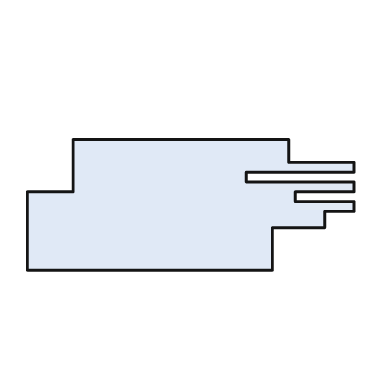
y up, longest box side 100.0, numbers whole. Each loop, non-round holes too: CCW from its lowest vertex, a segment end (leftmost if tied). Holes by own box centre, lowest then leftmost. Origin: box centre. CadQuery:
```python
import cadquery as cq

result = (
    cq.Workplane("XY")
    .moveTo(-50.0, -20.0)
    .lineTo(25.0, -20.0)
    .lineTo(25.0, -7.0)
    .lineTo(41.0, -7.0)
    .lineTo(41.0, -2.0)
    .lineTo(50.0, -2.0)
    .lineTo(50.0, 1.0)
    .lineTo(32.0, 1.0)
    .lineTo(32.0, 4.0)
    .lineTo(50.0, 4.0)
    .lineTo(50.0, 7.0)
    .lineTo(17.0, 7.0)
    .lineTo(17.0, 10.0)
    .lineTo(50.0, 10.0)
    .lineTo(50.0, 13.0)
    .lineTo(30.0, 13.0)
    .lineTo(30.0, 20.0)
    .lineTo(-36.0, 20.0)
    .lineTo(-36.0, 4.0)
    .lineTo(-50.0, 4.0)
    .close()
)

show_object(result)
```